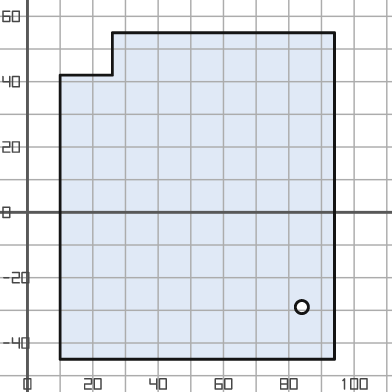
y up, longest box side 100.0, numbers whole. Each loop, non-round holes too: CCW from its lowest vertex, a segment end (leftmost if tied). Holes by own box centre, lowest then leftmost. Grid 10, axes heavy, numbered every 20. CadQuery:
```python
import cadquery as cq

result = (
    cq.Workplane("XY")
    .moveTo(10.0, -45.0)
    .lineTo(94.0, -45.0)
    .lineTo(94.0, 55.0)
    .lineTo(26.0, 55.0)
    .lineTo(26.0, 42.0)
    .lineTo(10.0, 42.0)
    .close()
    .moveTo(84.0, -29.0)
    .circle(2.0)
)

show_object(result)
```